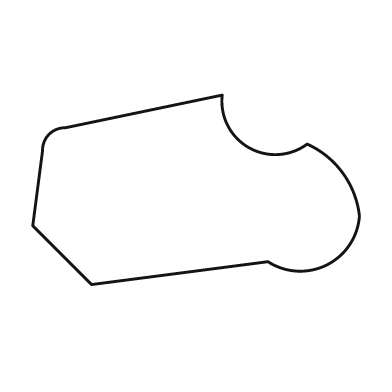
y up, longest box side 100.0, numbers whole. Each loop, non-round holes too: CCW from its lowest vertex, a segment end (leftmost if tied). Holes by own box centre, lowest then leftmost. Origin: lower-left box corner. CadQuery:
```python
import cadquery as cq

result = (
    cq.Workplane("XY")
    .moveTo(18.0, 0.0)
    .lineTo(72.0, 7.0)
    .threePointArc((90.0, 6.0), (100.0, 21.0))
    .threePointArc((95.0, 34.0), (84.0, 43.0))
    .threePointArc((66.0, 42.0), (58.0, 58.0))
    .lineTo(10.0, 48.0)
    .threePointArc((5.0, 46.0), (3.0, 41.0))
    .lineTo(0.0, 18.0)
    .close()
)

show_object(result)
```